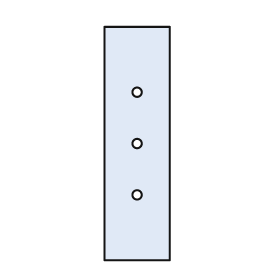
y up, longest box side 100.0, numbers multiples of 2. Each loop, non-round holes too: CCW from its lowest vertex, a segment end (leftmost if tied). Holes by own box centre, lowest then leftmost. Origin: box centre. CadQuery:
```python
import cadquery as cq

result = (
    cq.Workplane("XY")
    .moveTo(-14.0, -50.0)
    .lineTo(14.0, -50.0)
    .lineTo(14.0, 50.0)
    .lineTo(-14.0, 50.0)
    .close()
    .moveTo(0.0, -22.0)
    .circle(2.0)
    .moveTo(0.0, 0.0)
    .circle(2.0)
    .moveTo(0.0, 22.0)
    .circle(2.0)
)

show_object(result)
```